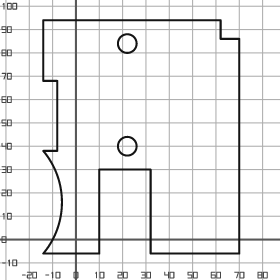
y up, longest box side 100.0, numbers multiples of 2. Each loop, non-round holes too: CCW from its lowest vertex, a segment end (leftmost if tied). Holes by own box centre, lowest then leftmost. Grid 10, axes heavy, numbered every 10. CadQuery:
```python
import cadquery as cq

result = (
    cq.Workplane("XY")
    .moveTo(-14.0, -6.0)
    .lineTo(10.0, -6.0)
    .lineTo(10.0, 30.0)
    .lineTo(32.0, 30.0)
    .lineTo(32.0, -6.0)
    .lineTo(70.0, -6.0)
    .lineTo(70.0, 86.0)
    .lineTo(62.0, 86.0)
    .lineTo(62.0, 94.0)
    .lineTo(-14.0, 94.0)
    .lineTo(-14.0, 68.0)
    .lineTo(-8.0, 68.0)
    .lineTo(-8.0, 38.0)
    .lineTo(-14.0, 38.0)
    .threePointArc((-6.0, 16.0), (-14.0, -6.0))
    .close()
    .moveTo(22.0, 40.0)
    .circle(4.0)
    .moveTo(22.0, 84.0)
    .circle(4.0)
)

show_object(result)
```